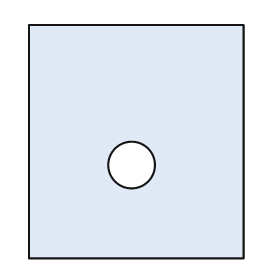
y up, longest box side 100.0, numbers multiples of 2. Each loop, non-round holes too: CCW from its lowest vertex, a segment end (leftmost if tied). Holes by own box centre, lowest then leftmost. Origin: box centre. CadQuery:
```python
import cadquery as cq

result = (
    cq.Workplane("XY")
    .moveTo(-46.0, -50.0)
    .lineTo(46.0, -50.0)
    .lineTo(46.0, 50.0)
    .lineTo(-46.0, 50.0)
    .close()
    .moveTo(-2.0, -10.0)
    .circle(10.0)
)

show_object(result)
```